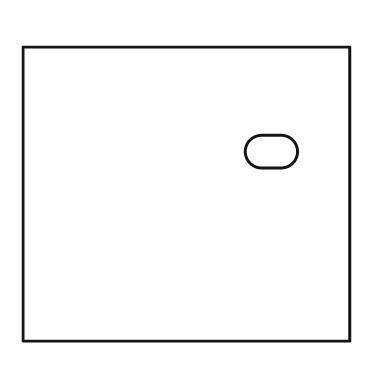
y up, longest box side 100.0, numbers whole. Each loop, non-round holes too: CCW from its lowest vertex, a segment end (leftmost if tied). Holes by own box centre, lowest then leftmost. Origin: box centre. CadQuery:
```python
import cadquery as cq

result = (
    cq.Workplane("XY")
    .moveTo(-50.0, -45.0)
    .lineTo(50.0, -45.0)
    .lineTo(50.0, 45.0)
    .lineTo(-50.0, 45.0)
    .close()
    .moveTo(23.0, 8.0)
    .lineTo(29.0, 8.0)
    .threePointArc((34.0, 13.0), (29.0, 18.0))
    .lineTo(23.0, 18.0)
    .threePointArc((18.0, 13.0), (23.0, 8.0))
    .close()
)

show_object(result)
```